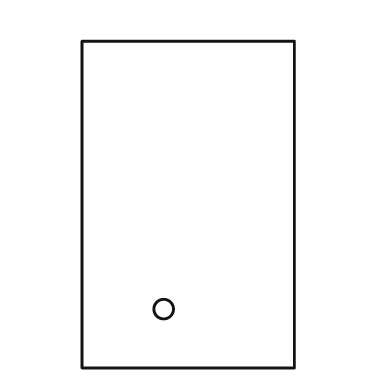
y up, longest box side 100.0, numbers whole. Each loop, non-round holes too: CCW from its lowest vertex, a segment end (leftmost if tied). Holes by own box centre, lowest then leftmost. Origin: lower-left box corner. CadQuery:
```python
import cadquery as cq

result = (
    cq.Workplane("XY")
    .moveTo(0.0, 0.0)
    .lineTo(65.0, 0.0)
    .lineTo(65.0, 100.0)
    .lineTo(0.0, 100.0)
    .close()
    .moveTo(25.0, 18.0)
    .circle(3.0)
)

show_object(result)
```